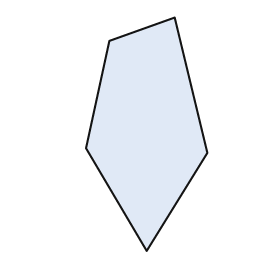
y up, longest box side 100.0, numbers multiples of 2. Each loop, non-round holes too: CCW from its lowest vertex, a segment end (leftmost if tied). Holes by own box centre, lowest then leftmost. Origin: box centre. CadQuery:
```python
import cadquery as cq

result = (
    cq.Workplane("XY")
    .moveTo(0.0, -50.0)
    .lineTo(26.0, -8.0)
    .lineTo(12.0, 50.0)
    .lineTo(-16.0, 40.0)
    .lineTo(-26.0, -6.0)
    .close()
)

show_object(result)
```